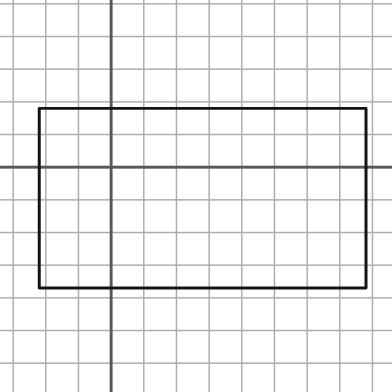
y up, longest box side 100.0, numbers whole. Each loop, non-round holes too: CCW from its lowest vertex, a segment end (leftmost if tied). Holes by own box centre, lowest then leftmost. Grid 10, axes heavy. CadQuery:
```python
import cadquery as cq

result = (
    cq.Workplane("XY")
    .moveTo(-22.0, -37.0)
    .lineTo(78.0, -37.0)
    .lineTo(78.0, 18.0)
    .lineTo(-22.0, 18.0)
    .close()
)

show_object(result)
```